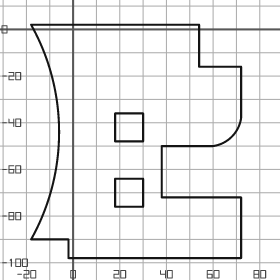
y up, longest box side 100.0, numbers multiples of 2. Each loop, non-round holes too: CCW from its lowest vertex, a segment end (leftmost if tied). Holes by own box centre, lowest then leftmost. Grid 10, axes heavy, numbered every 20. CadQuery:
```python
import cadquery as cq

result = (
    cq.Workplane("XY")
    .moveTo(-2.0, -98.0)
    .lineTo(72.0, -98.0)
    .lineTo(72.0, -72.0)
    .lineTo(38.0, -72.0)
    .lineTo(38.0, -50.0)
    .lineTo(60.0, -50.0)
    .threePointArc((68.0, -46.0), (72.0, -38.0))
    .lineTo(72.0, -16.0)
    .lineTo(54.0, -16.0)
    .lineTo(54.0, 2.0)
    .lineTo(-18.0, 2.0)
    .threePointArc((-6.0, -44.0), (-18.0, -90.0))
    .lineTo(-2.0, -90.0)
    .close()
    .moveTo(18.0, -76.0)
    .lineTo(30.0, -76.0)
    .lineTo(30.0, -64.0)
    .lineTo(18.0, -64.0)
    .close()
    .moveTo(18.0, -48.0)
    .lineTo(30.0, -48.0)
    .lineTo(30.0, -36.0)
    .lineTo(18.0, -36.0)
    .close()
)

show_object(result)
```